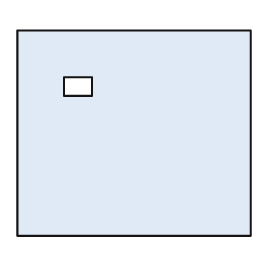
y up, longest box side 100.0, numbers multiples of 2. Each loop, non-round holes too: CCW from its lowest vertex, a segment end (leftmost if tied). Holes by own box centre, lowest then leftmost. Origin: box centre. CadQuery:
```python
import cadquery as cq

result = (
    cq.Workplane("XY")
    .moveTo(-50.0, -44.0)
    .lineTo(50.0, -44.0)
    .lineTo(50.0, 44.0)
    .lineTo(-50.0, 44.0)
    .close()
    .moveTo(-30.0, 16.0)
    .lineTo(-18.0, 16.0)
    .lineTo(-18.0, 24.0)
    .lineTo(-30.0, 24.0)
    .close()
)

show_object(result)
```